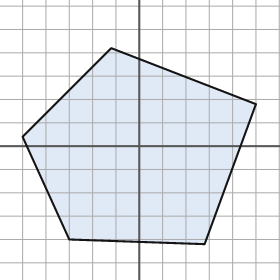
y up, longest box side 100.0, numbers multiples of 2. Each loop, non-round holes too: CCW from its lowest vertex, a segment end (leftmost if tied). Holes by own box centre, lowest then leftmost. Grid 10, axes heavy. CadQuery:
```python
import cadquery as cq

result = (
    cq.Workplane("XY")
    .moveTo(28.0, -42.0)
    .lineTo(50.0, 18.0)
    .lineTo(-12.0, 42.0)
    .lineTo(-50.0, 4.0)
    .lineTo(-30.0, -40.0)
    .close()
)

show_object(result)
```